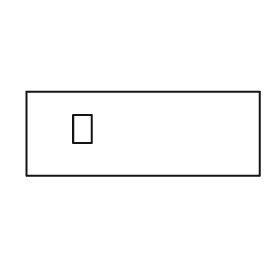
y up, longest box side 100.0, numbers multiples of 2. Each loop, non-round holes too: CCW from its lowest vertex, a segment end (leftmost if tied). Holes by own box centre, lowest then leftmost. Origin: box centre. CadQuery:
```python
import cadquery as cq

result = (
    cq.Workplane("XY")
    .moveTo(-50.0, -18.0)
    .lineTo(50.0, -18.0)
    .lineTo(50.0, 18.0)
    .lineTo(-50.0, 18.0)
    .close()
    .moveTo(-30.0, -4.0)
    .lineTo(-22.0, -4.0)
    .lineTo(-22.0, 8.0)
    .lineTo(-30.0, 8.0)
    .close()
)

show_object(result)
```